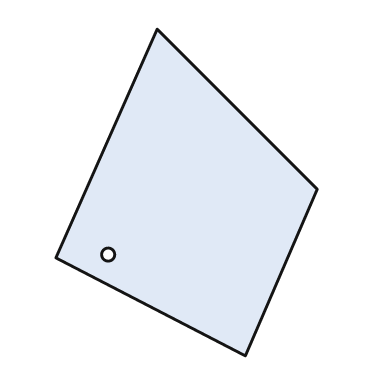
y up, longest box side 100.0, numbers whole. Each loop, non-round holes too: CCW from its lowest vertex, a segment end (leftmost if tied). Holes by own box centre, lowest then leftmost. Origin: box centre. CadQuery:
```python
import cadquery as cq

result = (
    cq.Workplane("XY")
    .moveTo(18.0, -50.0)
    .lineTo(40.0, 1.0)
    .lineTo(-9.0, 50.0)
    .lineTo(-40.0, -20.0)
    .close()
    .moveTo(-24.0, -19.0)
    .circle(2.0)
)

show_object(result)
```